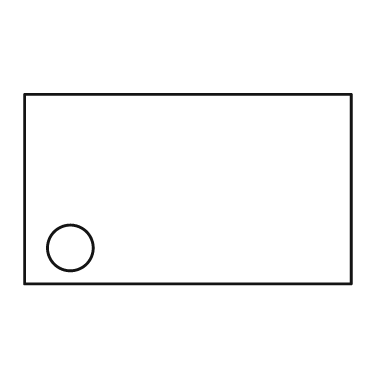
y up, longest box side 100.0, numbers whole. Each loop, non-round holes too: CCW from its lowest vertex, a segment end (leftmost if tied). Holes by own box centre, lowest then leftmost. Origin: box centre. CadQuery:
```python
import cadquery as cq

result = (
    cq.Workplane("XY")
    .moveTo(-50.0, -29.0)
    .lineTo(50.0, -29.0)
    .lineTo(50.0, 29.0)
    .lineTo(-50.0, 29.0)
    .close()
    .moveTo(-36.0, -18.0)
    .circle(7.0)
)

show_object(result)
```